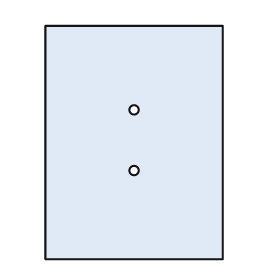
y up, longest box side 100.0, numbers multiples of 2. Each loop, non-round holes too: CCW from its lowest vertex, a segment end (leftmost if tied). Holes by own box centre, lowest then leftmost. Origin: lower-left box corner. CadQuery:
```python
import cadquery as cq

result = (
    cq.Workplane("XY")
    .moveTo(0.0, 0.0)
    .lineTo(76.0, 0.0)
    .lineTo(76.0, 100.0)
    .lineTo(0.0, 100.0)
    .close()
    .moveTo(38.0, 38.0)
    .circle(2.0)
    .moveTo(38.0, 64.0)
    .circle(2.0)
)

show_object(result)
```